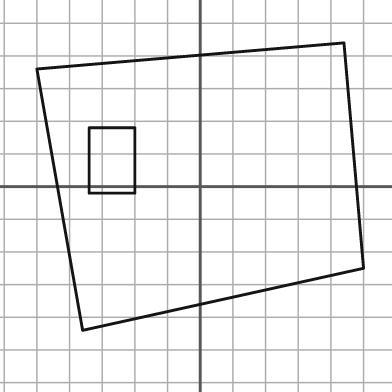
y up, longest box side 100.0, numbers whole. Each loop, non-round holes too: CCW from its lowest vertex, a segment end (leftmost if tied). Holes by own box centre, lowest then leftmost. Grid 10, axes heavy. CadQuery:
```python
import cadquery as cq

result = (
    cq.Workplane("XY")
    .moveTo(-36.0, -44.0)
    .lineTo(50.0, -25.0)
    .lineTo(44.0, 44.0)
    .lineTo(-50.0, 36.0)
    .close()
    .moveTo(-34.0, -2.0)
    .lineTo(-20.0, -2.0)
    .lineTo(-20.0, 18.0)
    .lineTo(-34.0, 18.0)
    .close()
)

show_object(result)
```